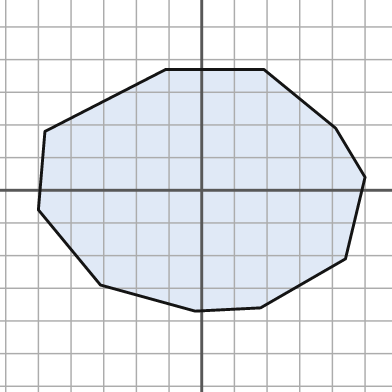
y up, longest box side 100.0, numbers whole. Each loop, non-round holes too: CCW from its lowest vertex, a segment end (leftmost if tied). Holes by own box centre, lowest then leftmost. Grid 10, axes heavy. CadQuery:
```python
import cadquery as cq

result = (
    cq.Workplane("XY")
    .moveTo(-2.0, -37.0)
    .lineTo(18.0, -36.0)
    .lineTo(44.0, -21.0)
    .lineTo(50.0, 4.0)
    .lineTo(41.0, 19.0)
    .lineTo(19.0, 37.0)
    .lineTo(-11.0, 37.0)
    .lineTo(-48.0, 18.0)
    .lineTo(-50.0, -6.0)
    .lineTo(-31.0, -29.0)
    .close()
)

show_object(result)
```